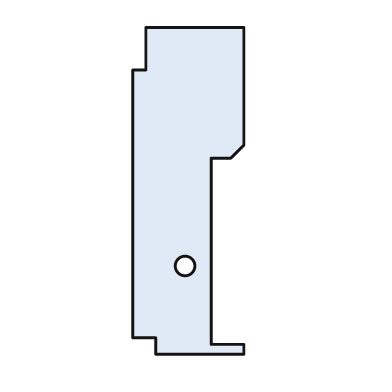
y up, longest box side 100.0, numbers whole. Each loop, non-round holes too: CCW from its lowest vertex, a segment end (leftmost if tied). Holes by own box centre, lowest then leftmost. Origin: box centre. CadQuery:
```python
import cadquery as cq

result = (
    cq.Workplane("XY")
    .moveTo(-10.0, -50.0)
    .lineTo(17.0, -50.0)
    .lineTo(17.0, -47.0)
    .lineTo(7.0, -47.0)
    .lineTo(7.0, 10.0)
    .lineTo(13.0, 10.0)
    .lineTo(17.0, 14.0)
    .lineTo(17.0, 50.0)
    .lineTo(-13.0, 50.0)
    .lineTo(-13.0, 37.0)
    .lineTo(-17.0, 37.0)
    .lineTo(-17.0, -45.0)
    .lineTo(-10.0, -45.0)
    .close()
    .moveTo(-1.0, -23.0)
    .circle(3.0)
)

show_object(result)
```